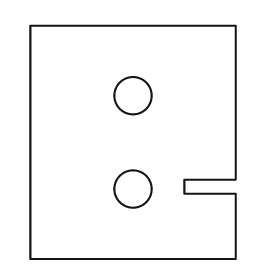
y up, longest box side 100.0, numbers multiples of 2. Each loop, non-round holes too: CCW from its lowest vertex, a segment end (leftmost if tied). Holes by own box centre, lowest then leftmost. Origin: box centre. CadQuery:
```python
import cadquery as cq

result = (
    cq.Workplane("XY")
    .moveTo(-44.0, -50.0)
    .lineTo(44.0, -50.0)
    .lineTo(44.0, -22.0)
    .lineTo(22.0, -22.0)
    .lineTo(22.0, -16.0)
    .lineTo(44.0, -16.0)
    .lineTo(44.0, 50.0)
    .lineTo(-44.0, 50.0)
    .close()
    .moveTo(0.0, -20.0)
    .circle(8.0)
    .moveTo(0.0, 20.0)
    .circle(8.0)
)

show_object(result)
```